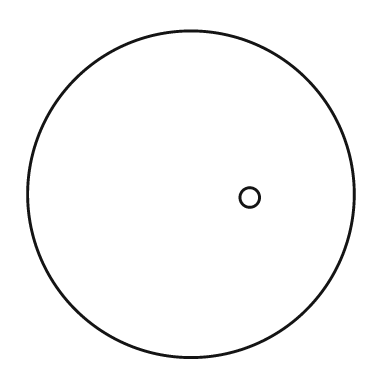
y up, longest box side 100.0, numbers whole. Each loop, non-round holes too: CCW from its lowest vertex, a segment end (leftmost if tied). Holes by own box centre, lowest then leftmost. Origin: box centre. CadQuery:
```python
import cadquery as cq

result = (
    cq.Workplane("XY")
    .moveTo(0.0, 0.0)
    .circle(50.0)
    .moveTo(18.0, -1.0)
    .circle(3.0)
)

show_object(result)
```